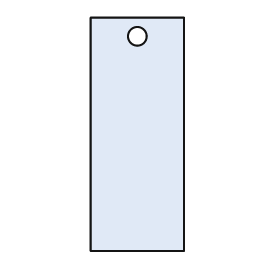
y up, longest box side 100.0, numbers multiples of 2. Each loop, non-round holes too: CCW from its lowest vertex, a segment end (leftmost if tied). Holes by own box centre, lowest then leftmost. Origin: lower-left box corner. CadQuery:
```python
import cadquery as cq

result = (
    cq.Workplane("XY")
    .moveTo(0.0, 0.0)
    .lineTo(40.0, 0.0)
    .lineTo(40.0, 100.0)
    .lineTo(0.0, 100.0)
    .close()
    .moveTo(20.0, 92.0)
    .circle(4.0)
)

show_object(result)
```